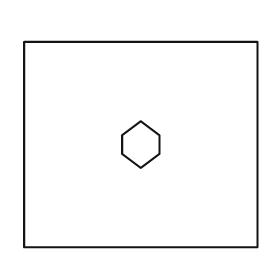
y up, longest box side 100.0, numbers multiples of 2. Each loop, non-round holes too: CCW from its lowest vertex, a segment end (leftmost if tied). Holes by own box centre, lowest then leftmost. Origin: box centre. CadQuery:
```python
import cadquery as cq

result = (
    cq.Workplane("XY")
    .moveTo(-50.0, -44.0)
    .lineTo(50.0, -44.0)
    .lineTo(50.0, 44.0)
    .lineTo(-50.0, 44.0)
    .close()
    .moveTo(0.0, -10.0)
    .lineTo(8.0, -4.0)
    .lineTo(8.0, 4.0)
    .lineTo(0.0, 10.0)
    .lineTo(-8.0, 4.0)
    .lineTo(-8.0, -4.0)
    .close()
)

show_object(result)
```